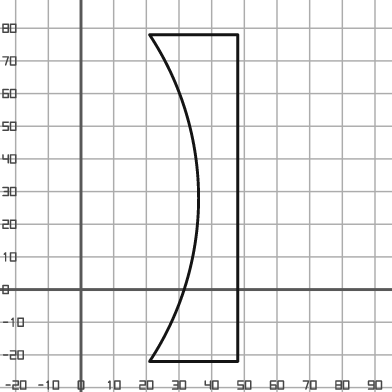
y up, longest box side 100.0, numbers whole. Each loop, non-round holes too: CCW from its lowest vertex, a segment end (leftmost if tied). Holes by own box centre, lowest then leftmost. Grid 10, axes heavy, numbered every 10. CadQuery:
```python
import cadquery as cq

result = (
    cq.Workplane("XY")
    .moveTo(21.0, -22.0)
    .lineTo(48.0, -22.0)
    .lineTo(48.0, 78.0)
    .lineTo(21.0, 78.0)
    .threePointArc((36.0, 28.0), (21.0, -22.0))
    .close()
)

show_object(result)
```